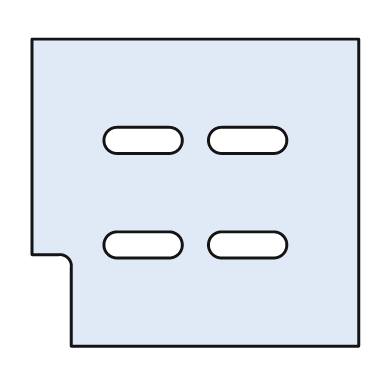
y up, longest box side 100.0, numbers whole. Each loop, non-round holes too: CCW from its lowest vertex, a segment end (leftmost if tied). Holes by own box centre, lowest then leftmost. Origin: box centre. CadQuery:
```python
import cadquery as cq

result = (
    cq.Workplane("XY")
    .moveTo(-38.0, -47.0)
    .lineTo(50.0, -47.0)
    .lineTo(50.0, 47.0)
    .lineTo(-50.0, 47.0)
    .lineTo(-50.0, -19.0)
    .lineTo(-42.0, -19.0)
    .threePointArc((-39.0, -20.0), (-38.0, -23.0))
    .close()
    .moveTo(-24.0, -20.0)
    .lineTo(-8.0, -20.0)
    .threePointArc((-4.0, -16.0), (-8.0, -12.0))
    .lineTo(-24.0, -12.0)
    .threePointArc((-28.0, -16.0), (-24.0, -20.0))
    .close()
    .moveTo(8.0, -20.0)
    .lineTo(24.0, -20.0)
    .threePointArc((28.0, -16.0), (24.0, -12.0))
    .lineTo(8.0, -12.0)
    .threePointArc((4.0, -16.0), (8.0, -20.0))
    .close()
    .moveTo(-24.0, 12.0)
    .lineTo(-8.0, 12.0)
    .threePointArc((-4.0, 16.0), (-8.0, 20.0))
    .lineTo(-24.0, 20.0)
    .threePointArc((-28.0, 16.0), (-24.0, 12.0))
    .close()
    .moveTo(8.0, 12.0)
    .lineTo(24.0, 12.0)
    .threePointArc((28.0, 16.0), (24.0, 20.0))
    .lineTo(8.0, 20.0)
    .threePointArc((4.0, 16.0), (8.0, 12.0))
    .close()
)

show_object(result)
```